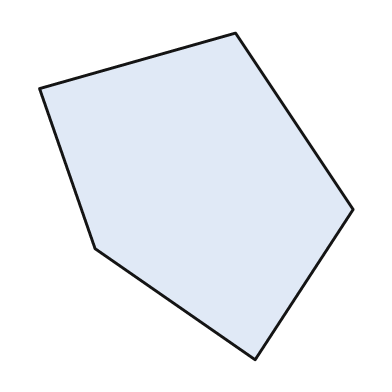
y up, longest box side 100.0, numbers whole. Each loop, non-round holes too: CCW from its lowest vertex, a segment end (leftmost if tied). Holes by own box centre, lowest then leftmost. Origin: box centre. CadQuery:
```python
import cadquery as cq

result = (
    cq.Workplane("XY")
    .moveTo(18.0, -50.0)
    .lineTo(48.0, -4.0)
    .lineTo(12.0, 50.0)
    .lineTo(-48.0, 33.0)
    .lineTo(-31.0, -16.0)
    .close()
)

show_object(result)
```